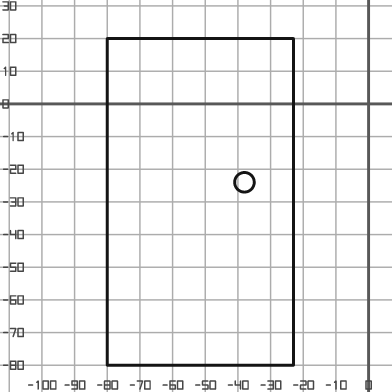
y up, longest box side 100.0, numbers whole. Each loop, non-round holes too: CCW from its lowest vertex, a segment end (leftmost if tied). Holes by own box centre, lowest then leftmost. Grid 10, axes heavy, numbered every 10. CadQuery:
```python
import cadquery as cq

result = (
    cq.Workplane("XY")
    .moveTo(-80.0, -80.0)
    .lineTo(-23.0, -80.0)
    .lineTo(-23.0, 20.0)
    .lineTo(-80.0, 20.0)
    .close()
    .moveTo(-38.0, -24.0)
    .circle(3.0)
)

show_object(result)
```